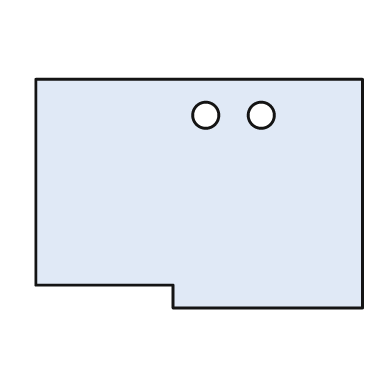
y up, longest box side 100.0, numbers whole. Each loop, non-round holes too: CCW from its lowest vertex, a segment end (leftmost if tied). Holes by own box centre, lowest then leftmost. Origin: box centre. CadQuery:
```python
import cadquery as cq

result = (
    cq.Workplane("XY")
    .moveTo(-8.0, -35.0)
    .lineTo(50.0, -35.0)
    .lineTo(50.0, 35.0)
    .lineTo(-50.0, 35.0)
    .lineTo(-50.0, -28.0)
    .lineTo(-8.0, -28.0)
    .close()
    .moveTo(2.0, 24.0)
    .circle(4.0)
    .moveTo(19.0, 24.0)
    .circle(4.0)
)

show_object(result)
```